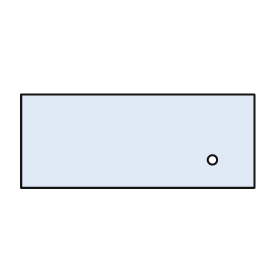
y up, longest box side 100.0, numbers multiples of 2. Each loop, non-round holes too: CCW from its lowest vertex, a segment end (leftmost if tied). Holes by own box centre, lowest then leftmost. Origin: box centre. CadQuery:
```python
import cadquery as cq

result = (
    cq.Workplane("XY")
    .moveTo(-50.0, -20.0)
    .lineTo(50.0, -20.0)
    .lineTo(50.0, 20.0)
    .lineTo(-50.0, 20.0)
    .close()
    .moveTo(32.0, -8.0)
    .circle(2.0)
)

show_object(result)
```